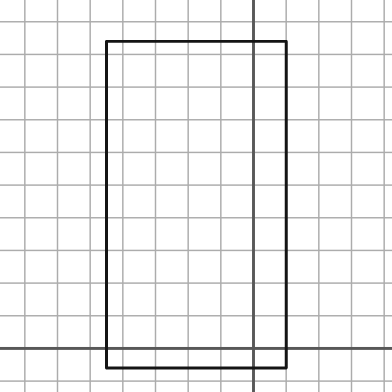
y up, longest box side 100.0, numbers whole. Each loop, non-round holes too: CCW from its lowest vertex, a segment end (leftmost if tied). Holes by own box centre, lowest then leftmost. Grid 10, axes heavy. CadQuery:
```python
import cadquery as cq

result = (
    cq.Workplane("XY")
    .moveTo(-45.0, -6.0)
    .lineTo(10.0, -6.0)
    .lineTo(10.0, 94.0)
    .lineTo(-45.0, 94.0)
    .close()
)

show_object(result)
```